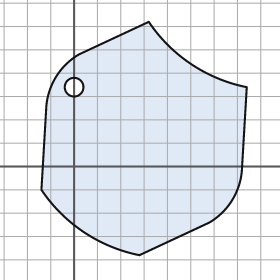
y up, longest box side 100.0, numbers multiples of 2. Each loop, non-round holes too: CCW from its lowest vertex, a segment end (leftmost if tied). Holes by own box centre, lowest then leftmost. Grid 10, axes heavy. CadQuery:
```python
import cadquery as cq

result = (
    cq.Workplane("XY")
    .moveTo(28.0, -38.0)
    .lineTo(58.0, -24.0)
    .threePointArc((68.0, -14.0), (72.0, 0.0))
    .lineTo(74.0, 34.0)
    .threePointArc((50.0, 44.0), (32.0, 62.0))
    .lineTo(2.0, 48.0)
    .threePointArc((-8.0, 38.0), (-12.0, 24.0))
    .lineTo(-14.0, -10.0)
    .threePointArc((4.0, -28.0), (28.0, -38.0))
    .close()
    .moveTo(0.0, 34.0)
    .circle(4.0)
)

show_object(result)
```